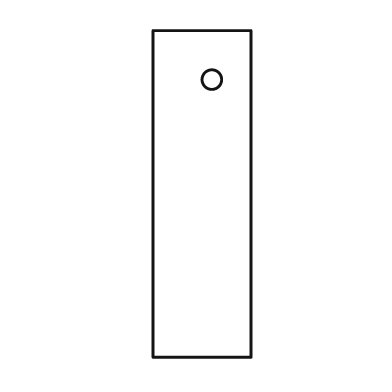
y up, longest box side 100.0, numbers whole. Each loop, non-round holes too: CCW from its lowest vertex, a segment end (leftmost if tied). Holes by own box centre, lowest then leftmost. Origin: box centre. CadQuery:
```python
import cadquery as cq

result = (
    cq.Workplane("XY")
    .moveTo(-15.0, -50.0)
    .lineTo(15.0, -50.0)
    .lineTo(15.0, 50.0)
    .lineTo(-15.0, 50.0)
    .close()
    .moveTo(3.0, 35.0)
    .circle(3.0)
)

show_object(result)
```